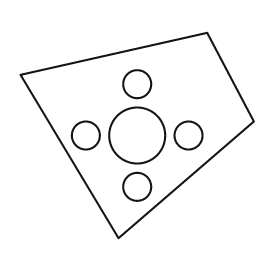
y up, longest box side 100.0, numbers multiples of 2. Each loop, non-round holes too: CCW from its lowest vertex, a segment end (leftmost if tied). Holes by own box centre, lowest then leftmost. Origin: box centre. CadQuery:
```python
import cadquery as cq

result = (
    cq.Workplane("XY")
    .moveTo(-8.0, -44.0)
    .lineTo(50.0, 6.0)
    .lineTo(30.0, 44.0)
    .lineTo(-50.0, 26.0)
    .close()
    .moveTo(0.0, -22.0)
    .circle(6.0)
    .moveTo(-22.0, 0.0)
    .circle(6.0)
    .moveTo(0.0, 0.0)
    .circle(12.0)
    .moveTo(22.0, 0.0)
    .circle(6.0)
    .moveTo(0.0, 22.0)
    .circle(6.0)
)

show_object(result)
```